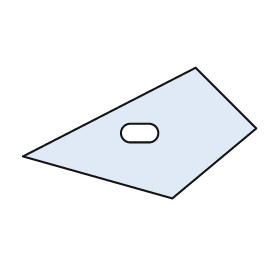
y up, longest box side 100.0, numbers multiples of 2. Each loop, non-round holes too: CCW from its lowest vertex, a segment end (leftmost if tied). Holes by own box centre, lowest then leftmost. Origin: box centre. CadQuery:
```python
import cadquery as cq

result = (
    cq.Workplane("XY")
    .moveTo(14.0, -28.0)
    .lineTo(50.0, 2.0)
    .lineTo(24.0, 28.0)
    .lineTo(-50.0, -10.0)
    .close()
    .moveTo(-4.0, -4.0)
    .lineTo(4.0, -4.0)
    .threePointArc((8.0, 0.0), (4.0, 4.0))
    .lineTo(-4.0, 4.0)
    .threePointArc((-8.0, 0.0), (-4.0, -4.0))
    .close()
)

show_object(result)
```